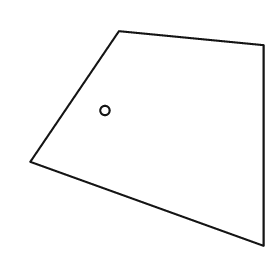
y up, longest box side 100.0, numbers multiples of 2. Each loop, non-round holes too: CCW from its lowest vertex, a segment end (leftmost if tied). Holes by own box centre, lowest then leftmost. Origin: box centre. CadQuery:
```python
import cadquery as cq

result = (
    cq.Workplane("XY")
    .moveTo(50.0, -46.0)
    .lineTo(50.0, 40.0)
    .lineTo(-12.0, 46.0)
    .lineTo(-50.0, -10.0)
    .close()
    .moveTo(-18.0, 12.0)
    .circle(2.0)
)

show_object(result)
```